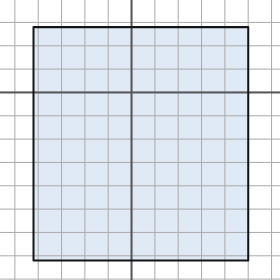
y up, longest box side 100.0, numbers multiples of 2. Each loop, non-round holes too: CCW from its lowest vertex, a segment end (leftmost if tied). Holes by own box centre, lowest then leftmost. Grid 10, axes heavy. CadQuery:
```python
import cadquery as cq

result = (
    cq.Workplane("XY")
    .moveTo(-42.0, -72.0)
    .lineTo(50.0, -72.0)
    .lineTo(50.0, 28.0)
    .lineTo(-42.0, 28.0)
    .close()
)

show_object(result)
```